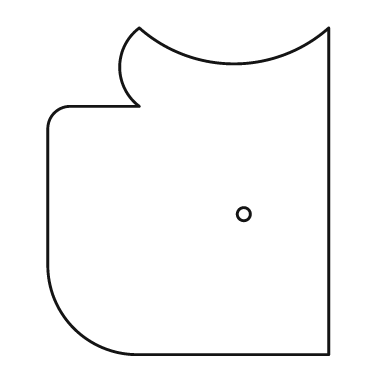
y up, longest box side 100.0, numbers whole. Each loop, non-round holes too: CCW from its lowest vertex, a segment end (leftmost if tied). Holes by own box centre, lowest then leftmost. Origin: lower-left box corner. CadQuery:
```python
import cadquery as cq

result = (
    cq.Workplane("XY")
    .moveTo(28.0, 0.0)
    .lineTo(86.0, 0.0)
    .lineTo(86.0, 100.0)
    .threePointArc((57.0, 89.0), (28.0, 100.0))
    .threePointArc((22.0, 88.0), (28.0, 76.0))
    .lineTo(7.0, 76.0)
    .threePointArc((2.0, 74.0), (0.0, 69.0))
    .lineTo(0.0, 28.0)
    .threePointArc((8.0, 8.0), (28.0, 0.0))
    .close()
    .moveTo(60.0, 43.0)
    .circle(2.0)
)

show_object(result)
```